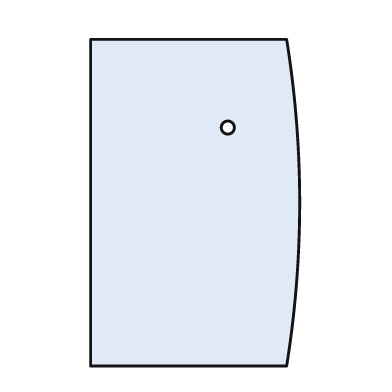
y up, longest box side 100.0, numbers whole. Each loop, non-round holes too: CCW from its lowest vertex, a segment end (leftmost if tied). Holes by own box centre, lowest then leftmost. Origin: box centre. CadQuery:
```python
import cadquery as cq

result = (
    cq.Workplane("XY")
    .moveTo(-32.0, -50.0)
    .lineTo(28.0, -50.0)
    .threePointArc((32.0, 0.0), (28.0, 50.0))
    .lineTo(-32.0, 50.0)
    .close()
    .moveTo(10.0, 23.0)
    .circle(2.0)
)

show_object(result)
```